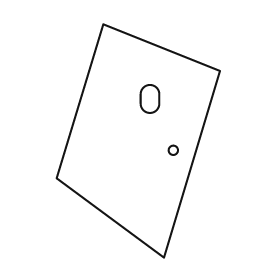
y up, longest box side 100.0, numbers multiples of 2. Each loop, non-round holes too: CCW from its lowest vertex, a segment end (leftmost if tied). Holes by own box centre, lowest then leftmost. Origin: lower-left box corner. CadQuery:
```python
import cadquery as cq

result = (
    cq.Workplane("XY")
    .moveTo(46.0, 0.0)
    .lineTo(70.0, 80.0)
    .lineTo(20.0, 100.0)
    .lineTo(0.0, 34.0)
    .close()
    .moveTo(50.0, 46.0)
    .circle(2.0)
    .moveTo(36.0, 66.0)
    .threePointArc((40.0, 62.0), (44.0, 66.0))
    .lineTo(44.0, 70.0)
    .threePointArc((40.0, 74.0), (36.0, 70.0))
    .close()
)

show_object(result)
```